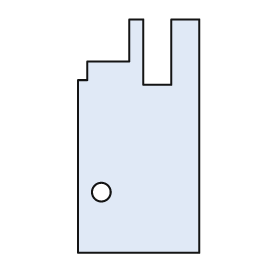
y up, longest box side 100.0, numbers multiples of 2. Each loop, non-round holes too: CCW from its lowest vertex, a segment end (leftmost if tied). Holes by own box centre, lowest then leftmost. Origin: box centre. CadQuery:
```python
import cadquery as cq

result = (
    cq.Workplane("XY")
    .moveTo(-26.0, -50.0)
    .lineTo(26.0, -50.0)
    .lineTo(26.0, 50.0)
    .lineTo(14.0, 50.0)
    .lineTo(14.0, 22.0)
    .lineTo(2.0, 22.0)
    .lineTo(2.0, 50.0)
    .lineTo(-4.0, 50.0)
    .lineTo(-4.0, 32.0)
    .lineTo(-22.0, 32.0)
    .lineTo(-22.0, 24.0)
    .lineTo(-26.0, 24.0)
    .close()
    .moveTo(-16.0, -24.0)
    .circle(4.0)
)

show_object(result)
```